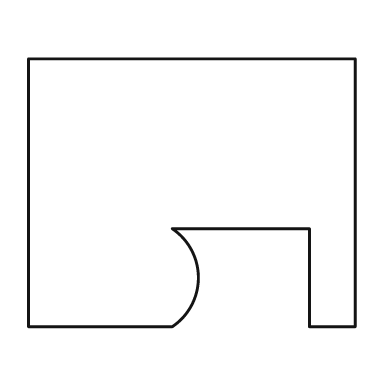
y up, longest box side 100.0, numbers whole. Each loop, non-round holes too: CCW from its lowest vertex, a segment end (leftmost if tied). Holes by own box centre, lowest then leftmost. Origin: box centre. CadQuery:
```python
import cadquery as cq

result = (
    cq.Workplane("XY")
    .moveTo(-50.0, -41.0)
    .lineTo(-6.0, -41.0)
    .threePointArc((2.0, -26.0), (-6.0, -11.0))
    .lineTo(36.0, -11.0)
    .lineTo(36.0, -41.0)
    .lineTo(50.0, -41.0)
    .lineTo(50.0, 41.0)
    .lineTo(-50.0, 41.0)
    .close()
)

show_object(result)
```